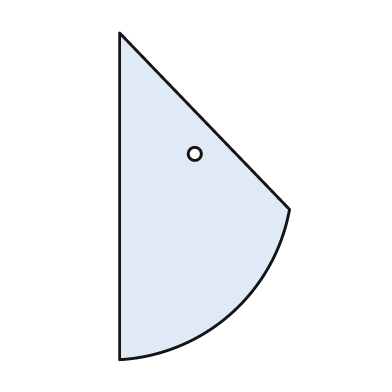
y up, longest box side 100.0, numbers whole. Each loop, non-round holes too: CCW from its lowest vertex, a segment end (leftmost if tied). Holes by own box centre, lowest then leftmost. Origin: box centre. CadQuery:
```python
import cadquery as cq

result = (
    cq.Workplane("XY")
    .moveTo(-26.0, -50.0)
    .threePointArc((8.0, -36.0), (26.0, -4.0))
    .lineTo(-26.0, 50.0)
    .close()
    .moveTo(-3.0, 13.0)
    .circle(2.0)
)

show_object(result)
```